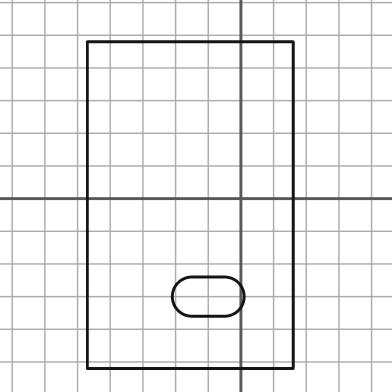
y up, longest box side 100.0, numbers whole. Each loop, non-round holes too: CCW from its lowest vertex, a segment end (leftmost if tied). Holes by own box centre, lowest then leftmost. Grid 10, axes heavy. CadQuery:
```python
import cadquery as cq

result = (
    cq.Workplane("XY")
    .moveTo(-47.0, -52.0)
    .lineTo(16.0, -52.0)
    .lineTo(16.0, 48.0)
    .lineTo(-47.0, 48.0)
    .close()
    .moveTo(-15.0, -36.0)
    .lineTo(-5.0, -36.0)
    .threePointArc((1.0, -30.0), (-5.0, -24.0))
    .lineTo(-15.0, -24.0)
    .threePointArc((-21.0, -30.0), (-15.0, -36.0))
    .close()
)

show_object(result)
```